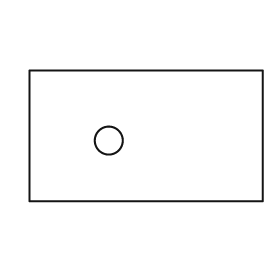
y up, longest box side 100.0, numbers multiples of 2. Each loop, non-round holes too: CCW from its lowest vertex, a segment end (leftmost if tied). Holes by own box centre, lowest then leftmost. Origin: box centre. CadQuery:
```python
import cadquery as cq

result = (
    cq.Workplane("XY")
    .moveTo(-50.0, -28.0)
    .lineTo(50.0, -28.0)
    .lineTo(50.0, 28.0)
    .lineTo(-50.0, 28.0)
    .close()
    .moveTo(-16.0, -2.0)
    .circle(6.0)
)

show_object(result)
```